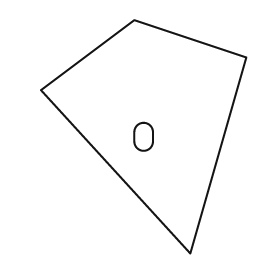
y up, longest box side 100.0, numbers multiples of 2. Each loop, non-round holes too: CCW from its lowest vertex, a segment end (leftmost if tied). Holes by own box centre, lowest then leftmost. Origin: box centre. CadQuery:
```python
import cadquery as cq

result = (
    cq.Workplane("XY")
    .moveTo(20.0, -50.0)
    .lineTo(44.0, 34.0)
    .lineTo(-4.0, 50.0)
    .lineTo(-44.0, 20.0)
    .close()
    .moveTo(-4.0, -2.0)
    .threePointArc((0.0, -6.0), (4.0, -2.0))
    .lineTo(4.0, 2.0)
    .threePointArc((0.0, 6.0), (-4.0, 2.0))
    .close()
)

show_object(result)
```